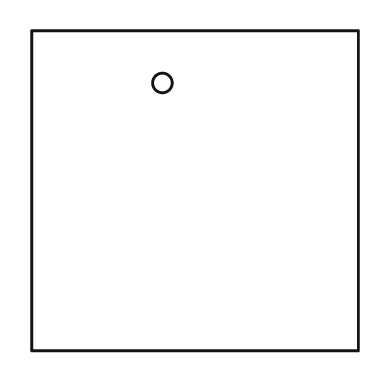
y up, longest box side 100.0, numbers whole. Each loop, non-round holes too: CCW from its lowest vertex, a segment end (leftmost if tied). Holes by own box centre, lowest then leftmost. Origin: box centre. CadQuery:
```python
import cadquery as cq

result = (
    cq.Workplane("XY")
    .moveTo(-50.0, -49.0)
    .lineTo(50.0, -49.0)
    .lineTo(50.0, 49.0)
    .lineTo(-50.0, 49.0)
    .close()
    .moveTo(-10.0, 33.0)
    .circle(3.0)
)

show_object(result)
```